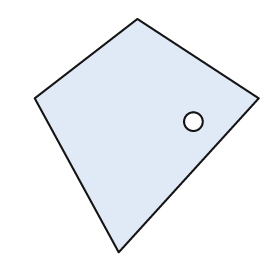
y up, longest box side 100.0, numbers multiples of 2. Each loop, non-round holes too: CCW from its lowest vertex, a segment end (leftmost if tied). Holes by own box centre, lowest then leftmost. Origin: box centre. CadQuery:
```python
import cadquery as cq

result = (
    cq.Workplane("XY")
    .moveTo(-12.0, -50.0)
    .lineTo(48.0, 16.0)
    .lineTo(-4.0, 50.0)
    .lineTo(-48.0, 16.0)
    .close()
    .moveTo(20.0, 6.0)
    .circle(4.0)
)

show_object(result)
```